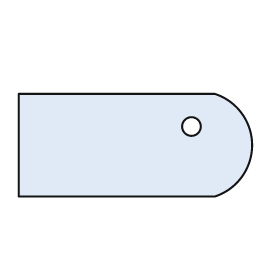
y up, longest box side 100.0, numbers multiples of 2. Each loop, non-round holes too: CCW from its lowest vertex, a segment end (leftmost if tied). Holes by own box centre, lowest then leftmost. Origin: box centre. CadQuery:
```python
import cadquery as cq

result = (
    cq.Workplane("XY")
    .moveTo(-50.0, -22.0)
    .lineTo(34.0, -22.0)
    .threePointArc((50.0, 0.0), (34.0, 22.0))
    .lineTo(-50.0, 22.0)
    .close()
    .moveTo(24.0, 8.0)
    .circle(4.0)
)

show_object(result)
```